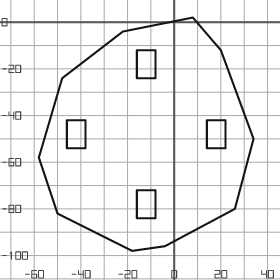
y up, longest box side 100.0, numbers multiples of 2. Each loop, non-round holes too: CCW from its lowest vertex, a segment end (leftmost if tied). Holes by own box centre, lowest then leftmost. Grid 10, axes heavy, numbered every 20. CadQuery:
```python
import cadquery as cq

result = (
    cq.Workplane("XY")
    .moveTo(-18.0, -98.0)
    .lineTo(-4.0, -96.0)
    .lineTo(26.0, -80.0)
    .lineTo(34.0, -50.0)
    .lineTo(20.0, -12.0)
    .lineTo(8.0, 2.0)
    .lineTo(-22.0, -4.0)
    .lineTo(-48.0, -24.0)
    .lineTo(-58.0, -58.0)
    .lineTo(-50.0, -82.0)
    .close()
    .moveTo(-16.0, -84.0)
    .lineTo(-8.0, -84.0)
    .lineTo(-8.0, -72.0)
    .lineTo(-16.0, -72.0)
    .close()
    .moveTo(-46.0, -54.0)
    .lineTo(-38.0, -54.0)
    .lineTo(-38.0, -42.0)
    .lineTo(-46.0, -42.0)
    .close()
    .moveTo(14.0, -54.0)
    .lineTo(22.0, -54.0)
    .lineTo(22.0, -42.0)
    .lineTo(14.0, -42.0)
    .close()
    .moveTo(-16.0, -24.0)
    .lineTo(-8.0, -24.0)
    .lineTo(-8.0, -12.0)
    .lineTo(-16.0, -12.0)
    .close()
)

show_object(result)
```